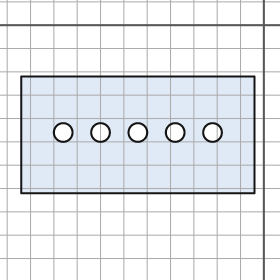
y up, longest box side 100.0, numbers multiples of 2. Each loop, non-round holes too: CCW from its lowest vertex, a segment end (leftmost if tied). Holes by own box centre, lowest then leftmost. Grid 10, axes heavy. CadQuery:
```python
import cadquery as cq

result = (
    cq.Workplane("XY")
    .moveTo(-104.0, -72.0)
    .lineTo(-4.0, -72.0)
    .lineTo(-4.0, -22.0)
    .lineTo(-104.0, -22.0)
    .close()
    .moveTo(-86.0, -46.0)
    .circle(4.0)
    .moveTo(-70.0, -46.0)
    .circle(4.0)
    .moveTo(-54.0, -46.0)
    .circle(4.0)
    .moveTo(-38.0, -46.0)
    .circle(4.0)
    .moveTo(-22.0, -46.0)
    .circle(4.0)
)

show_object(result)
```